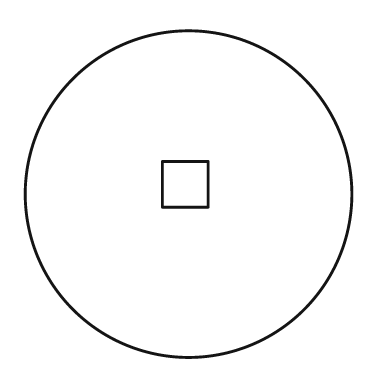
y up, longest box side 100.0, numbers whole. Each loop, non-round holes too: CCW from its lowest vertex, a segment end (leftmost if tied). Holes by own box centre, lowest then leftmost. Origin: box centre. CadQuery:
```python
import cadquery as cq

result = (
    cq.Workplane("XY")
    .moveTo(0.0, 0.0)
    .circle(50.0)
    .moveTo(-8.0, -4.0)
    .lineTo(6.0, -4.0)
    .lineTo(6.0, 10.0)
    .lineTo(-8.0, 10.0)
    .close()
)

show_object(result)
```